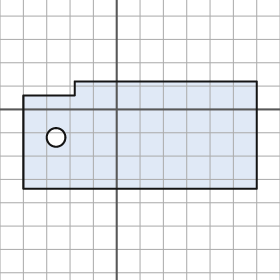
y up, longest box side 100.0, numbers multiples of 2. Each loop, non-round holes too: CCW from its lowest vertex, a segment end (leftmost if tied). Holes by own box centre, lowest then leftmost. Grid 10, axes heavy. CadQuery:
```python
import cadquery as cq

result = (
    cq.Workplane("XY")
    .moveTo(-40.0, -34.0)
    .lineTo(60.0, -34.0)
    .lineTo(60.0, 12.0)
    .lineTo(-18.0, 12.0)
    .lineTo(-18.0, 6.0)
    .lineTo(-40.0, 6.0)
    .close()
    .moveTo(-26.0, -12.0)
    .circle(4.0)
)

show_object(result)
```